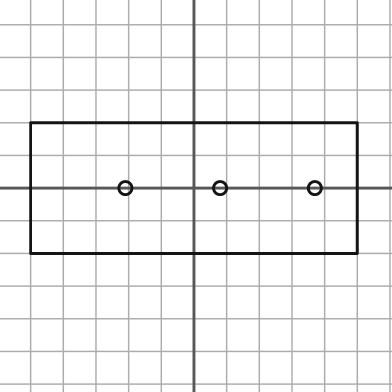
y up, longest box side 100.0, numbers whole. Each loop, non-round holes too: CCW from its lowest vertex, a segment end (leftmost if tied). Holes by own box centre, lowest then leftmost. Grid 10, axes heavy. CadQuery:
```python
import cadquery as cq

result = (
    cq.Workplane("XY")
    .moveTo(-50.0, -20.0)
    .lineTo(50.0, -20.0)
    .lineTo(50.0, 20.0)
    .lineTo(-50.0, 20.0)
    .close()
    .moveTo(-21.0, 0.0)
    .circle(2.0)
    .moveTo(8.0, 0.0)
    .circle(2.0)
    .moveTo(37.0, 0.0)
    .circle(2.0)
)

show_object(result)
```